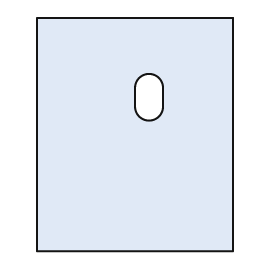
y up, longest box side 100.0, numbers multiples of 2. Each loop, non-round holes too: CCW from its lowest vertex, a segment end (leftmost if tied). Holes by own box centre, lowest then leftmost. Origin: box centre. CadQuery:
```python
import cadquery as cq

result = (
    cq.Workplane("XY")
    .moveTo(-42.0, -50.0)
    .lineTo(42.0, -50.0)
    .lineTo(42.0, 50.0)
    .lineTo(-42.0, 50.0)
    .close()
    .moveTo(0.0, 12.0)
    .threePointArc((6.0, 6.0), (12.0, 12.0))
    .lineTo(12.0, 20.0)
    .threePointArc((6.0, 26.0), (0.0, 20.0))
    .close()
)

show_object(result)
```